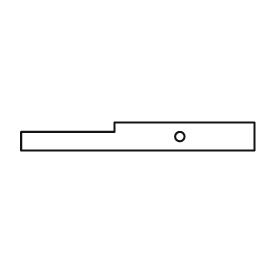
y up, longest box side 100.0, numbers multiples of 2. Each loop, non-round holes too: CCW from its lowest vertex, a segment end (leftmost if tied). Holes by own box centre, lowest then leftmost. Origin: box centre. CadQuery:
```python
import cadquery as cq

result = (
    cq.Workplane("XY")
    .moveTo(-50.0, -6.0)
    .lineTo(50.0, -6.0)
    .lineTo(50.0, 6.0)
    .lineTo(-10.0, 6.0)
    .lineTo(-10.0, 2.0)
    .lineTo(-50.0, 2.0)
    .close()
    .moveTo(18.0, 0.0)
    .circle(2.0)
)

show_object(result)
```